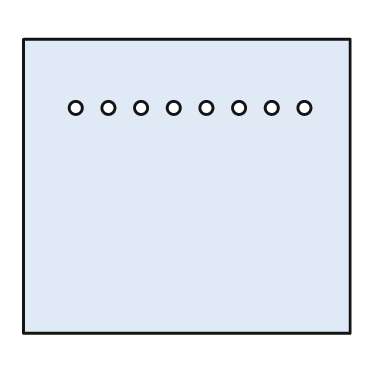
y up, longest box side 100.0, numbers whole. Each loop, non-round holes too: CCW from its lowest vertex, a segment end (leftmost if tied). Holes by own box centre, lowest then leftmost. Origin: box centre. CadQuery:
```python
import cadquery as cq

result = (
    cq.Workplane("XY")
    .moveTo(-50.0, -45.0)
    .lineTo(50.0, -45.0)
    .lineTo(50.0, 45.0)
    .lineTo(-50.0, 45.0)
    .close()
    .moveTo(-34.0, 24.0)
    .circle(2.0)
    .moveTo(-24.0, 24.0)
    .circle(2.0)
    .moveTo(-14.0, 24.0)
    .circle(2.0)
    .moveTo(-4.0, 24.0)
    .circle(2.0)
    .moveTo(6.0, 24.0)
    .circle(2.0)
    .moveTo(16.0, 24.0)
    .circle(2.0)
    .moveTo(26.0, 24.0)
    .circle(2.0)
    .moveTo(36.0, 24.0)
    .circle(2.0)
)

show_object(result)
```